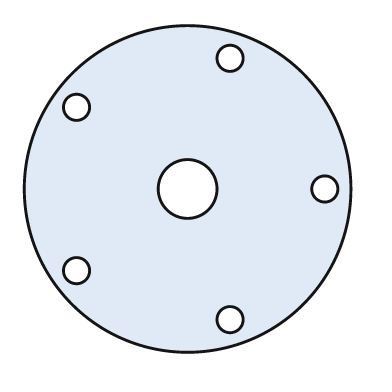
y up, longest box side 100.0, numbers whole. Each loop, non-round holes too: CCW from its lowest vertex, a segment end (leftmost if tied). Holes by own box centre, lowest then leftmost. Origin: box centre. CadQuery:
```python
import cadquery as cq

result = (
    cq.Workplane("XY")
    .moveTo(0.0, 0.0)
    .circle(50.0)
    .moveTo(13.0, -40.0)
    .circle(4.0)
    .moveTo(-34.0, -25.0)
    .circle(4.0)
    .moveTo(0.0, 0.0)
    .circle(9.0)
    .moveTo(42.0, 0.0)
    .circle(4.0)
    .moveTo(-34.0, 25.0)
    .circle(4.0)
    .moveTo(13.0, 40.0)
    .circle(4.0)
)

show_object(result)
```